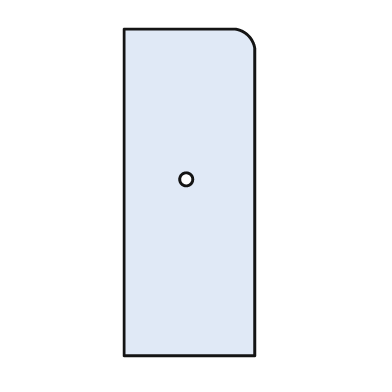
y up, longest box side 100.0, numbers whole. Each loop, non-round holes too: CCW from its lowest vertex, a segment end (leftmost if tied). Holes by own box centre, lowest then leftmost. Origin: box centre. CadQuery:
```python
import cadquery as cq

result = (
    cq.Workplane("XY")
    .moveTo(-20.0, -50.0)
    .lineTo(20.0, -50.0)
    .lineTo(20.0, 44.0)
    .threePointArc((18.0, 48.0), (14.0, 50.0))
    .lineTo(-20.0, 50.0)
    .close()
    .moveTo(-1.0, 4.0)
    .circle(2.0)
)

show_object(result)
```